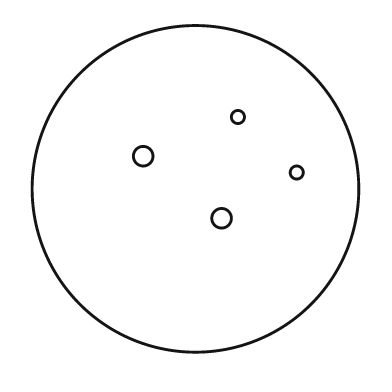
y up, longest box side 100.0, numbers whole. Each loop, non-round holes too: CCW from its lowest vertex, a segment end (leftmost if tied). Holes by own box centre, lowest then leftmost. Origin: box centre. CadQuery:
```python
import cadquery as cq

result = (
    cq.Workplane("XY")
    .moveTo(0.0, 0.0)
    .circle(50.0)
    .moveTo(8.0, -9.0)
    .circle(3.0)
    .moveTo(31.0, 5.0)
    .circle(2.0)
    .moveTo(-16.0, 10.0)
    .circle(3.0)
    .moveTo(13.0, 22.0)
    .circle(2.0)
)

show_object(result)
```